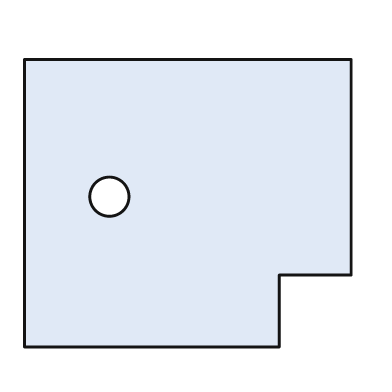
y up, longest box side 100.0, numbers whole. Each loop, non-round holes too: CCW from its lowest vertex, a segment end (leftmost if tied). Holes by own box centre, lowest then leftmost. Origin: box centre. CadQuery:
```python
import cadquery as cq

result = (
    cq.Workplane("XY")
    .moveTo(-50.0, -44.0)
    .lineTo(28.0, -44.0)
    .lineTo(28.0, -22.0)
    .lineTo(50.0, -22.0)
    .lineTo(50.0, 44.0)
    .lineTo(-50.0, 44.0)
    .close()
    .moveTo(-24.0, 2.0)
    .circle(6.0)
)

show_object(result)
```